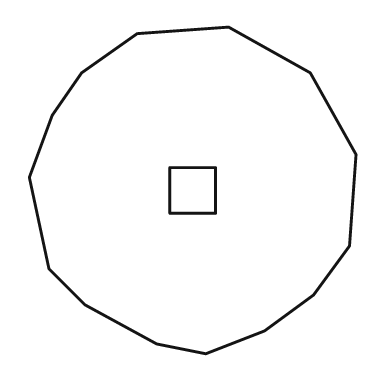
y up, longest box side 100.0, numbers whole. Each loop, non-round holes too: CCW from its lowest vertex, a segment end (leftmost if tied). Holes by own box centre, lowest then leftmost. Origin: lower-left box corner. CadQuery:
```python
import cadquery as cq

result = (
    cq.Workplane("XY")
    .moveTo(54.0, 0.0)
    .lineTo(72.0, 7.0)
    .lineTo(87.0, 18.0)
    .lineTo(98.0, 33.0)
    .lineTo(100.0, 61.0)
    .lineTo(86.0, 86.0)
    .lineTo(61.0, 100.0)
    .lineTo(33.0, 98.0)
    .lineTo(16.0, 86.0)
    .lineTo(7.0, 73.0)
    .lineTo(0.0, 54.0)
    .lineTo(6.0, 26.0)
    .lineTo(17.0, 15.0)
    .lineTo(39.0, 3.0)
    .close()
    .moveTo(43.0, 43.0)
    .lineTo(57.0, 43.0)
    .lineTo(57.0, 57.0)
    .lineTo(43.0, 57.0)
    .close()
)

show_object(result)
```